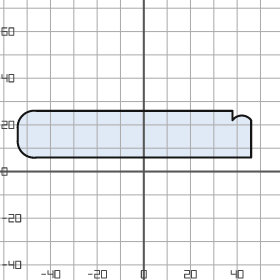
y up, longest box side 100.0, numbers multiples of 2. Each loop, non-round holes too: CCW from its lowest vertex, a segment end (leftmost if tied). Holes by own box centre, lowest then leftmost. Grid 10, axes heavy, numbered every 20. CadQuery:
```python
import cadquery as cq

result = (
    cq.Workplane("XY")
    .moveTo(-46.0, 6.0)
    .lineTo(46.0, 6.0)
    .lineTo(46.0, 22.0)
    .threePointArc((42.0, 24.0), (38.0, 22.0))
    .lineTo(38.0, 26.0)
    .lineTo(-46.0, 26.0)
    .threePointArc((-52.0, 24.0), (-54.0, 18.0))
    .lineTo(-54.0, 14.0)
    .threePointArc((-52.0, 8.0), (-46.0, 6.0))
    .close()
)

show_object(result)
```